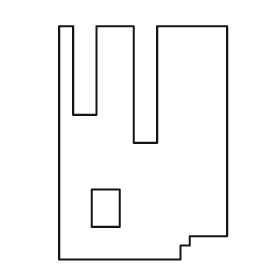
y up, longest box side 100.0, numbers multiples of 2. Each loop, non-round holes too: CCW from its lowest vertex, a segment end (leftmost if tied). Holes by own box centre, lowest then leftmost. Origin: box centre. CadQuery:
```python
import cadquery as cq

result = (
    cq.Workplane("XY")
    .moveTo(-36.0, -50.0)
    .lineTo(16.0, -50.0)
    .lineTo(16.0, -44.0)
    .lineTo(20.0, -44.0)
    .lineTo(20.0, -40.0)
    .lineTo(36.0, -40.0)
    .lineTo(36.0, 50.0)
    .lineTo(6.0, 50.0)
    .lineTo(6.0, 0.0)
    .lineTo(-4.0, 0.0)
    .lineTo(-4.0, 50.0)
    .lineTo(-20.0, 50.0)
    .lineTo(-20.0, 12.0)
    .lineTo(-30.0, 12.0)
    .lineTo(-30.0, 50.0)
    .lineTo(-36.0, 50.0)
    .close()
    .moveTo(-22.0, -36.0)
    .lineTo(-10.0, -36.0)
    .lineTo(-10.0, -20.0)
    .lineTo(-22.0, -20.0)
    .close()
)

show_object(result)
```